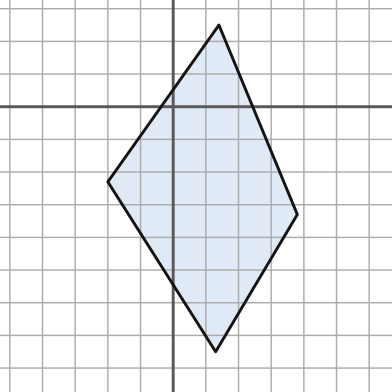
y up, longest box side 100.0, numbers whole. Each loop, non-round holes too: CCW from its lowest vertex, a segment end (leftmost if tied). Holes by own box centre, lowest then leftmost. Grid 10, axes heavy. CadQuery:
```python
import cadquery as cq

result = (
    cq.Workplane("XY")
    .moveTo(13.0, -75.0)
    .lineTo(38.0, -33.0)
    .lineTo(14.0, 25.0)
    .lineTo(-20.0, -23.0)
    .close()
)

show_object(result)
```